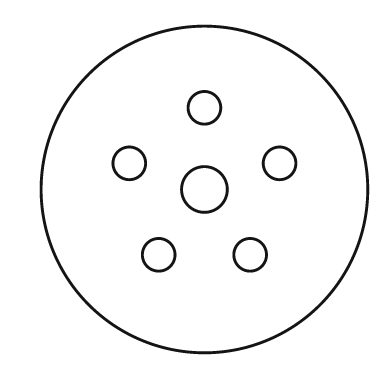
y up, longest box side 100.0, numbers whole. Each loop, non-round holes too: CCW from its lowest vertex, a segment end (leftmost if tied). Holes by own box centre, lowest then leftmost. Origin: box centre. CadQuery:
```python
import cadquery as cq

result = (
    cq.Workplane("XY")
    .moveTo(0.0, 0.0)
    .circle(50.0)
    .moveTo(-14.0, -20.0)
    .circle(5.0)
    .moveTo(14.0, -20.0)
    .circle(5.0)
    .moveTo(0.0, 0.0)
    .circle(7.0)
    .moveTo(-23.0, 8.0)
    .circle(5.0)
    .moveTo(23.0, 8.0)
    .circle(5.0)
    .moveTo(0.0, 25.0)
    .circle(5.0)
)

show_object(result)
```